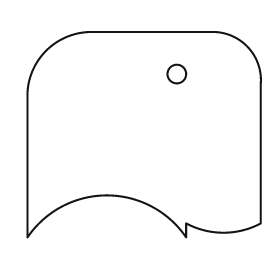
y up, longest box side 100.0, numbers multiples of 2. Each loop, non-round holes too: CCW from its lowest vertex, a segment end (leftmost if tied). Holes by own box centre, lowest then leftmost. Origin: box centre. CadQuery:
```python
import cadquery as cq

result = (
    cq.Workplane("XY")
    .moveTo(-50.0, -44.0)
    .threePointArc((-16.0, -26.0), (18.0, -44.0))
    .lineTo(18.0, -38.0)
    .threePointArc((34.0, -42.0), (50.0, -38.0))
    .lineTo(50.0, 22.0)
    .threePointArc((44.0, 38.0), (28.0, 44.0))
    .lineTo(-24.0, 44.0)
    .threePointArc((-42.0, 36.0), (-50.0, 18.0))
    .close()
    .moveTo(14.0, 26.0)
    .circle(4.0)
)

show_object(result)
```